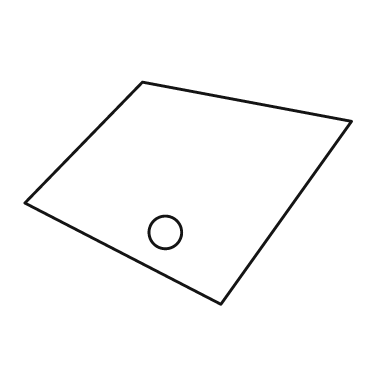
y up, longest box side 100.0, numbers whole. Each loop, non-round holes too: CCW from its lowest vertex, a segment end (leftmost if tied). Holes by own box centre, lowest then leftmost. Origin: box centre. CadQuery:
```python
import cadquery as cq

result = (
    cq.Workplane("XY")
    .moveTo(10.0, -34.0)
    .lineTo(50.0, 22.0)
    .lineTo(-14.0, 34.0)
    .lineTo(-50.0, -3.0)
    .close()
    .moveTo(-7.0, -12.0)
    .circle(5.0)
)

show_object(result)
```